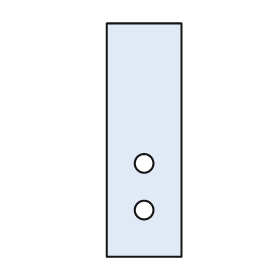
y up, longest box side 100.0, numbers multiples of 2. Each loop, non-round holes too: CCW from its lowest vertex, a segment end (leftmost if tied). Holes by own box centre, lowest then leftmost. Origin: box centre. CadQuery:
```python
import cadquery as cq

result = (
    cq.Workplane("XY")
    .moveTo(-16.0, -50.0)
    .lineTo(16.0, -50.0)
    .lineTo(16.0, 50.0)
    .lineTo(-16.0, 50.0)
    .close()
    .moveTo(0.0, -30.0)
    .circle(4.0)
    .moveTo(0.0, -10.0)
    .circle(4.0)
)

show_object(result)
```